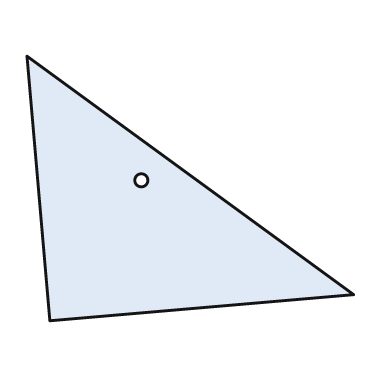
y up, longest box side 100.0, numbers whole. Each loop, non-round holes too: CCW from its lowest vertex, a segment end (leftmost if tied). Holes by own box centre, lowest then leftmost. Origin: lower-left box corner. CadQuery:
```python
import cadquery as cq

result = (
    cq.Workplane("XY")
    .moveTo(7.0, 0.0)
    .lineTo(100.0, 8.0)
    .lineTo(0.0, 81.0)
    .close()
    .moveTo(35.0, 43.0)
    .circle(2.0)
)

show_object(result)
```